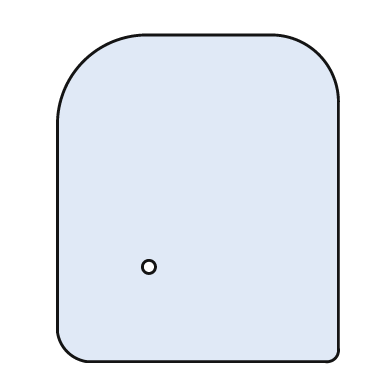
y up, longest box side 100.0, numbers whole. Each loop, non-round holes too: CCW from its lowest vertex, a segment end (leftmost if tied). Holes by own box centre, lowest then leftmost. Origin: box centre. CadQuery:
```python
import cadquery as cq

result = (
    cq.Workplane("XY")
    .moveTo(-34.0, -50.0)
    .lineTo(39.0, -50.0)
    .threePointArc((42.0, -49.0), (43.0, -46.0))
    .lineTo(43.0, 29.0)
    .threePointArc((37.0, 44.0), (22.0, 50.0))
    .lineTo(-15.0, 50.0)
    .threePointArc((-35.0, 42.0), (-43.0, 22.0))
    .lineTo(-43.0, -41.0)
    .threePointArc((-40.0, -47.0), (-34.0, -50.0))
    .close()
    .moveTo(-15.0, -21.0)
    .circle(2.0)
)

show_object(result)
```